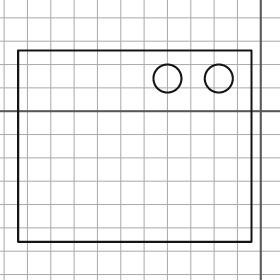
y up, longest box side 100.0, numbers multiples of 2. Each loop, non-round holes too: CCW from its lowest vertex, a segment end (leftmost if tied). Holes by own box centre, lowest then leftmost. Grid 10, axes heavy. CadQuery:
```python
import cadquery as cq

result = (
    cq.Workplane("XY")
    .moveTo(-104.0, -56.0)
    .lineTo(-4.0, -56.0)
    .lineTo(-4.0, 26.0)
    .lineTo(-104.0, 26.0)
    .close()
    .moveTo(-40.0, 14.0)
    .circle(6.0)
    .moveTo(-18.0, 14.0)
    .circle(6.0)
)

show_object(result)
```